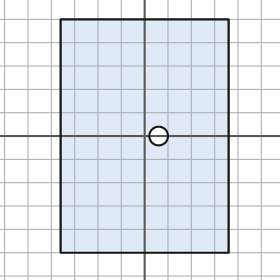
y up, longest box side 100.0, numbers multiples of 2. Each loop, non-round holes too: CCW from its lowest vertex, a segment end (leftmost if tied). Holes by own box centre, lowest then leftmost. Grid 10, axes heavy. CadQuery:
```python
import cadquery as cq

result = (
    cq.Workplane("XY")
    .moveTo(-36.0, -50.0)
    .lineTo(36.0, -50.0)
    .lineTo(36.0, 50.0)
    .lineTo(-36.0, 50.0)
    .close()
    .moveTo(6.0, 0.0)
    .circle(4.0)
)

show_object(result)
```